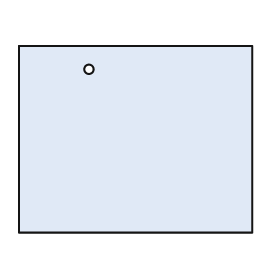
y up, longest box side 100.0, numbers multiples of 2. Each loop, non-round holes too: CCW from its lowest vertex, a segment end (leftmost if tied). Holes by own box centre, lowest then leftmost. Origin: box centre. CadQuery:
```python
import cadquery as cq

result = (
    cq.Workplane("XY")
    .moveTo(-50.0, -40.0)
    .lineTo(50.0, -40.0)
    .lineTo(50.0, 40.0)
    .lineTo(-50.0, 40.0)
    .close()
    .moveTo(-20.0, 30.0)
    .circle(2.0)
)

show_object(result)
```